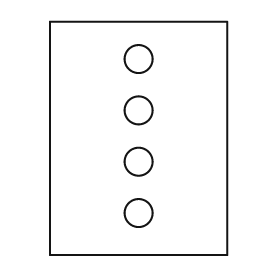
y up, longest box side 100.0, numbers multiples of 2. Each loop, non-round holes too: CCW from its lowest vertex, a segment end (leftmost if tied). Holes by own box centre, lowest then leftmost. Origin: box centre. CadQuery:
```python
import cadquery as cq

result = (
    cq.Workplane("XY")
    .moveTo(-38.0, -50.0)
    .lineTo(38.0, -50.0)
    .lineTo(38.0, 50.0)
    .lineTo(-38.0, 50.0)
    .close()
    .moveTo(0.0, -32.0)
    .circle(6.0)
    .moveTo(0.0, -10.0)
    .circle(6.0)
    .moveTo(0.0, 12.0)
    .circle(6.0)
    .moveTo(0.0, 34.0)
    .circle(6.0)
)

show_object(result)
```